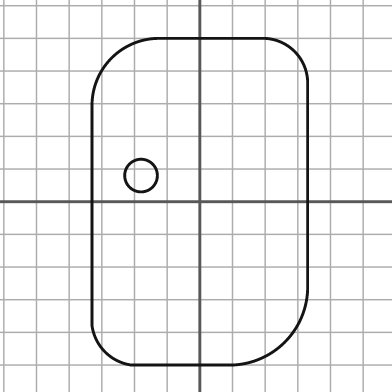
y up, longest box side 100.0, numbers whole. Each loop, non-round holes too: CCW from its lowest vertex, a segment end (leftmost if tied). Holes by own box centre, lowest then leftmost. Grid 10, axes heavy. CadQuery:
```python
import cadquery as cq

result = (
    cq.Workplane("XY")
    .moveTo(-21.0, -50.0)
    .lineTo(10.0, -50.0)
    .threePointArc((26.0, -43.0), (33.0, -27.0))
    .lineTo(33.0, 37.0)
    .threePointArc((29.0, 46.0), (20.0, 50.0))
    .lineTo(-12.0, 50.0)
    .threePointArc((-27.0, 44.0), (-33.0, 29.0))
    .lineTo(-33.0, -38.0)
    .threePointArc((-29.0, -46.0), (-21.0, -50.0))
    .close()
    .moveTo(-18.0, 8.0)
    .circle(5.0)
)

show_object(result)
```